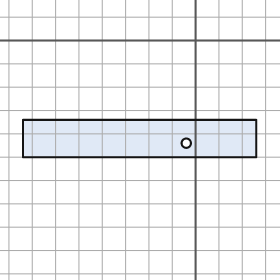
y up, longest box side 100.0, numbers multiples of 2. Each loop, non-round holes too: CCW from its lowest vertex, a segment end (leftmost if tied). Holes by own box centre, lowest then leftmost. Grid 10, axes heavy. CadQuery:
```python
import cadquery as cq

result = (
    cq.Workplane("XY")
    .moveTo(-74.0, -50.0)
    .lineTo(26.0, -50.0)
    .lineTo(26.0, -34.0)
    .lineTo(-74.0, -34.0)
    .close()
    .moveTo(-4.0, -44.0)
    .circle(2.0)
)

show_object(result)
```